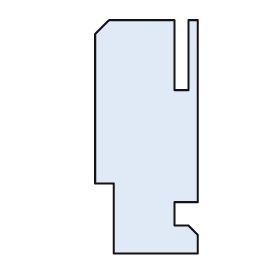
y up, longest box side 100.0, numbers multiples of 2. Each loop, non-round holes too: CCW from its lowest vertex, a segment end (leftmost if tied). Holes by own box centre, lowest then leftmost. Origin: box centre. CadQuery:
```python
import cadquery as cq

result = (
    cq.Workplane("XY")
    .moveTo(-14.0, -50.0)
    .lineTo(22.0, -50.0)
    .lineTo(22.0, -42.0)
    .lineTo(18.0, -38.0)
    .lineTo(12.0, -38.0)
    .lineTo(12.0, -28.0)
    .lineTo(22.0, -28.0)
    .lineTo(22.0, 50.0)
    .lineTo(18.0, 50.0)
    .lineTo(18.0, 20.0)
    .lineTo(12.0, 20.0)
    .lineTo(12.0, 50.0)
    .lineTo(-16.0, 50.0)
    .lineTo(-22.0, 44.0)
    .lineTo(-22.0, -20.0)
    .lineTo(-14.0, -20.0)
    .close()
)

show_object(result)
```